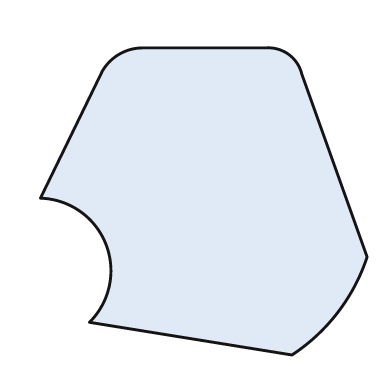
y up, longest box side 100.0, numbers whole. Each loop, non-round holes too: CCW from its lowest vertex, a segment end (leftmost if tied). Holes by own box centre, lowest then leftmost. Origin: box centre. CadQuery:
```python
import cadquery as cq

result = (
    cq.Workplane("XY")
    .moveTo(27.0, -47.0)
    .threePointArc((41.0, -34.0), (50.0, -17.0))
    .lineTo(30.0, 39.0)
    .threePointArc((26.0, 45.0), (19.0, 47.0))
    .lineTo(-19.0, 47.0)
    .threePointArc((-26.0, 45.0), (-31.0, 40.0))
    .lineTo(-50.0, 1.0)
    .threePointArc((-30.0, -13.0), (-35.0, -37.0))
    .close()
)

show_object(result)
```